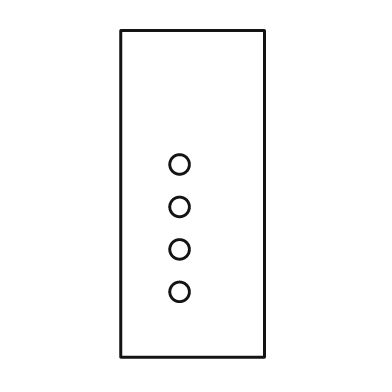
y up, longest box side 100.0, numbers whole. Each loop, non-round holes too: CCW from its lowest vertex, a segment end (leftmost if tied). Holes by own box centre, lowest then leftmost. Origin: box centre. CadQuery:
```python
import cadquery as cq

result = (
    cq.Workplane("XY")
    .moveTo(-22.0, -50.0)
    .lineTo(22.0, -50.0)
    .lineTo(22.0, 50.0)
    .lineTo(-22.0, 50.0)
    .close()
    .moveTo(-4.0, -30.0)
    .circle(3.0)
    .moveTo(-4.0, -17.0)
    .circle(3.0)
    .moveTo(-4.0, -4.0)
    .circle(3.0)
    .moveTo(-4.0, 9.0)
    .circle(3.0)
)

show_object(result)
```